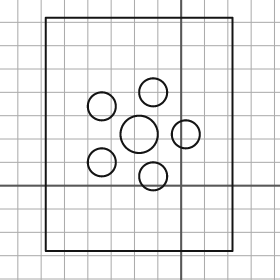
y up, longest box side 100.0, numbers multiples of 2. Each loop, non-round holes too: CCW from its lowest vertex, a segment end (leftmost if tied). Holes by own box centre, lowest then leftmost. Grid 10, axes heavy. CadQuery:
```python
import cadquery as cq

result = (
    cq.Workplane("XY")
    .moveTo(-58.0, -28.0)
    .lineTo(22.0, -28.0)
    .lineTo(22.0, 72.0)
    .lineTo(-58.0, 72.0)
    .close()
    .moveTo(-12.0, 4.0)
    .circle(6.0)
    .moveTo(-34.0, 10.0)
    .circle(6.0)
    .moveTo(-18.0, 22.0)
    .circle(8.0)
    .moveTo(2.0, 22.0)
    .circle(6.0)
    .moveTo(-34.0, 34.0)
    .circle(6.0)
    .moveTo(-12.0, 40.0)
    .circle(6.0)
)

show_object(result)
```